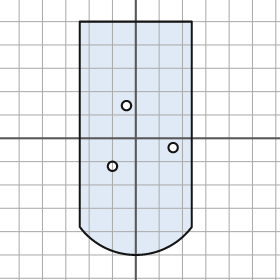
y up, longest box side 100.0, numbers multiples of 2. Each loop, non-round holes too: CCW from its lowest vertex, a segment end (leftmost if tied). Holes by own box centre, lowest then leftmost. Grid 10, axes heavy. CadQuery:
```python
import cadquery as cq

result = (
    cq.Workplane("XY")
    .moveTo(-24.0, -38.0)
    .threePointArc((0.0, -50.0), (24.0, -38.0))
    .lineTo(24.0, 50.0)
    .lineTo(-24.0, 50.0)
    .close()
    .moveTo(-10.0, -12.0)
    .circle(2.0)
    .moveTo(16.0, -4.0)
    .circle(2.0)
    .moveTo(-4.0, 14.0)
    .circle(2.0)
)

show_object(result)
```